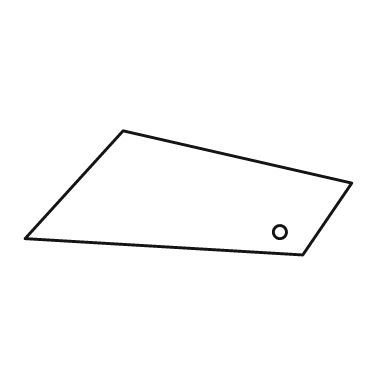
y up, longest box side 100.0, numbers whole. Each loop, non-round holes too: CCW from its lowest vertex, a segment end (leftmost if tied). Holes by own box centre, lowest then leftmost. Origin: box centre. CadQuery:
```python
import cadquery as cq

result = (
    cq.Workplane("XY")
    .moveTo(35.0, -19.0)
    .lineTo(50.0, 3.0)
    .lineTo(-20.0, 19.0)
    .lineTo(-50.0, -14.0)
    .close()
    .moveTo(28.0, -12.0)
    .circle(2.0)
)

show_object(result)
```